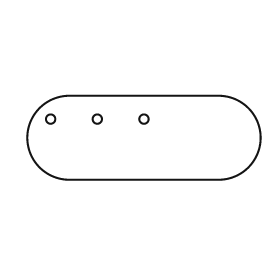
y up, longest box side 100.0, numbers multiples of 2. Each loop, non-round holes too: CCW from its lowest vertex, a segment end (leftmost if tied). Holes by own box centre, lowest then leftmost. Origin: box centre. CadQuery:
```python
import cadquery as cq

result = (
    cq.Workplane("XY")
    .moveTo(-32.0, -18.0)
    .lineTo(32.0, -18.0)
    .threePointArc((50.0, 0.0), (32.0, 18.0))
    .lineTo(-32.0, 18.0)
    .threePointArc((-50.0, 0.0), (-32.0, -18.0))
    .close()
    .moveTo(-40.0, 8.0)
    .circle(2.0)
    .moveTo(-20.0, 8.0)
    .circle(2.0)
    .moveTo(0.0, 8.0)
    .circle(2.0)
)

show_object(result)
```